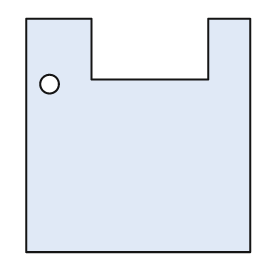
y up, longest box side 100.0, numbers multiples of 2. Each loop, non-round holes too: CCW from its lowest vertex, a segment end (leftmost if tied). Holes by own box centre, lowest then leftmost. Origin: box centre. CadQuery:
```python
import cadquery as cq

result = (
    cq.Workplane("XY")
    .moveTo(-48.0, -50.0)
    .lineTo(48.0, -50.0)
    .lineTo(48.0, 50.0)
    .lineTo(30.0, 50.0)
    .lineTo(30.0, 24.0)
    .lineTo(-20.0, 24.0)
    .lineTo(-20.0, 50.0)
    .lineTo(-48.0, 50.0)
    .close()
    .moveTo(-38.0, 22.0)
    .circle(4.0)
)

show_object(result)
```